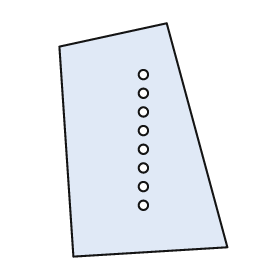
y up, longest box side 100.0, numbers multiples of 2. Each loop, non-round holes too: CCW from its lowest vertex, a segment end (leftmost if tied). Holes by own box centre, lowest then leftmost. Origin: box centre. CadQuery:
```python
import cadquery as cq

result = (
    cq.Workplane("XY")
    .moveTo(-30.0, -50.0)
    .lineTo(36.0, -46.0)
    .lineTo(10.0, 50.0)
    .lineTo(-36.0, 40.0)
    .close()
    .moveTo(0.0, -28.0)
    .circle(2.0)
    .moveTo(0.0, -20.0)
    .circle(2.0)
    .moveTo(0.0, -12.0)
    .circle(2.0)
    .moveTo(0.0, -4.0)
    .circle(2.0)
    .moveTo(0.0, 4.0)
    .circle(2.0)
    .moveTo(0.0, 12.0)
    .circle(2.0)
    .moveTo(0.0, 20.0)
    .circle(2.0)
    .moveTo(0.0, 28.0)
    .circle(2.0)
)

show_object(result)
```